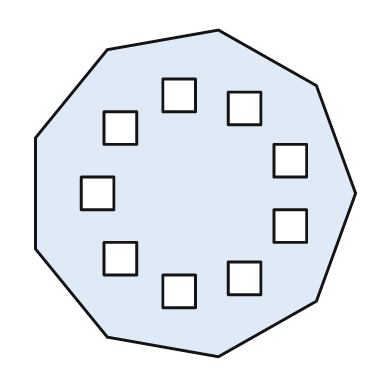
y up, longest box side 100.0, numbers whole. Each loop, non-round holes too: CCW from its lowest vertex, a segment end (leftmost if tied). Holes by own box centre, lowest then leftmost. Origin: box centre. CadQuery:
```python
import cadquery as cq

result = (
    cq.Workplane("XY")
    .moveTo(7.0, -50.0)
    .lineTo(37.0, -33.0)
    .lineTo(49.0, 0.0)
    .lineTo(37.0, 33.0)
    .lineTo(7.0, 50.0)
    .lineTo(-27.0, 44.0)
    .lineTo(-49.0, 17.0)
    .lineTo(-49.0, -17.0)
    .lineTo(-27.0, -44.0)
    .close()
    .moveTo(-10.0, -35.0)
    .lineTo(0.0, -35.0)
    .lineTo(0.0, -25.0)
    .lineTo(-10.0, -25.0)
    .close()
    .moveTo(10.0, -31.0)
    .lineTo(20.0, -31.0)
    .lineTo(20.0, -21.0)
    .lineTo(10.0, -21.0)
    .close()
    .moveTo(-28.0, -25.0)
    .lineTo(-18.0, -25.0)
    .lineTo(-18.0, -15.0)
    .lineTo(-28.0, -15.0)
    .close()
    .moveTo(24.0, -15.0)
    .lineTo(34.0, -15.0)
    .lineTo(34.0, -5.0)
    .lineTo(24.0, -5.0)
    .close()
    .moveTo(-35.0, -5.0)
    .lineTo(-25.0, -5.0)
    .lineTo(-25.0, 5.0)
    .lineTo(-35.0, 5.0)
    .close()
    .moveTo(24.0, 5.0)
    .lineTo(34.0, 5.0)
    .lineTo(34.0, 15.0)
    .lineTo(24.0, 15.0)
    .close()
    .moveTo(-28.0, 15.0)
    .lineTo(-18.0, 15.0)
    .lineTo(-18.0, 25.0)
    .lineTo(-28.0, 25.0)
    .close()
    .moveTo(10.0, 21.0)
    .lineTo(20.0, 21.0)
    .lineTo(20.0, 31.0)
    .lineTo(10.0, 31.0)
    .close()
    .moveTo(-10.0, 25.0)
    .lineTo(0.0, 25.0)
    .lineTo(0.0, 35.0)
    .lineTo(-10.0, 35.0)
    .close()
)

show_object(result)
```